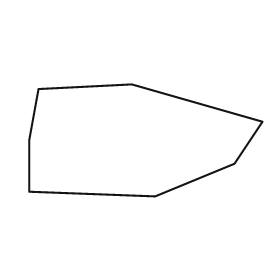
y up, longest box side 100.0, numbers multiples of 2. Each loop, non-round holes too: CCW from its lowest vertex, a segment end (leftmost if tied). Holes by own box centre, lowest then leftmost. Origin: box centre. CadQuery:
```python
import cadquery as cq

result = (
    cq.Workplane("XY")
    .moveTo(4.0, -24.0)
    .lineTo(38.0, -10.0)
    .lineTo(50.0, 8.0)
    .lineTo(-6.0, 24.0)
    .lineTo(-46.0, 22.0)
    .lineTo(-50.0, 0.0)
    .lineTo(-50.0, -22.0)
    .close()
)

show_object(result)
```